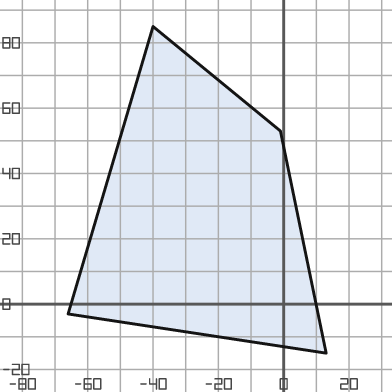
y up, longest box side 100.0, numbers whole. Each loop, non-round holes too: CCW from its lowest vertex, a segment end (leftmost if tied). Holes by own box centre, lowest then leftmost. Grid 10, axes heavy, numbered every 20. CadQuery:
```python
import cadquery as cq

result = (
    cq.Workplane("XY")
    .moveTo(13.0, -15.0)
    .lineTo(-1.0, 53.0)
    .lineTo(-40.0, 85.0)
    .lineTo(-66.0, -3.0)
    .close()
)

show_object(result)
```